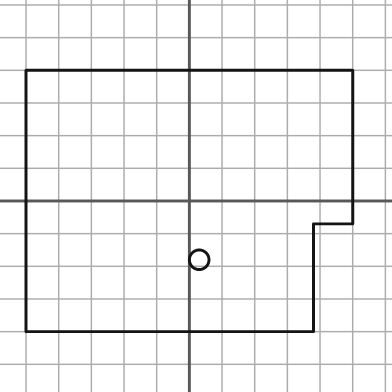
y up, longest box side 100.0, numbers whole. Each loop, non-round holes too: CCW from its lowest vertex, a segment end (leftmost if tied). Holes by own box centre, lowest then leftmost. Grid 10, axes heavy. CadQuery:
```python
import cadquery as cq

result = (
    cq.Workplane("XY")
    .moveTo(-50.0, -40.0)
    .lineTo(38.0, -40.0)
    .lineTo(38.0, -7.0)
    .lineTo(50.0, -7.0)
    .lineTo(50.0, 40.0)
    .lineTo(-50.0, 40.0)
    .close()
    .moveTo(3.0, -18.0)
    .circle(3.0)
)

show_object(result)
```